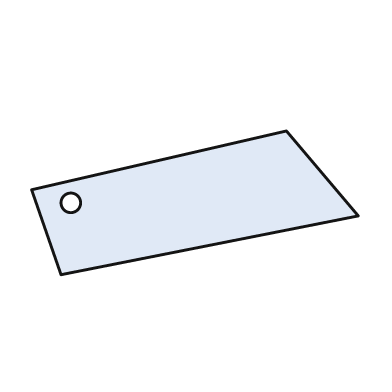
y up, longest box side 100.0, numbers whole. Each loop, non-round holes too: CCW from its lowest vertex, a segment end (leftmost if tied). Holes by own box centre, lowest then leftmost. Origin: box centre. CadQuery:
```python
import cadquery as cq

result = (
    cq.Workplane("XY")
    .moveTo(-41.0, -22.0)
    .lineTo(50.0, -4.0)
    .lineTo(28.0, 22.0)
    .lineTo(-50.0, 4.0)
    .close()
    .moveTo(-38.0, 0.0)
    .circle(3.0)
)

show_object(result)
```